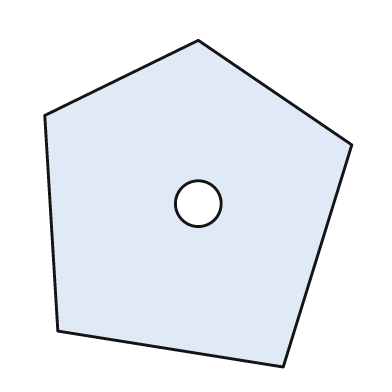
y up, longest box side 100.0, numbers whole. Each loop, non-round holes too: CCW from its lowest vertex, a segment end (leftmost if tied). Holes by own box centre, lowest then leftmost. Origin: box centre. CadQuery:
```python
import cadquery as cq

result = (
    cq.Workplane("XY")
    .moveTo(26.0, -50.0)
    .lineTo(47.0, 18.0)
    .lineTo(0.0, 50.0)
    .lineTo(-47.0, 27.0)
    .lineTo(-43.0, -39.0)
    .close()
    .moveTo(0.0, 0.0)
    .circle(7.0)
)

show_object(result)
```